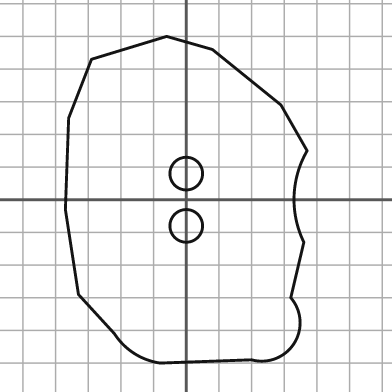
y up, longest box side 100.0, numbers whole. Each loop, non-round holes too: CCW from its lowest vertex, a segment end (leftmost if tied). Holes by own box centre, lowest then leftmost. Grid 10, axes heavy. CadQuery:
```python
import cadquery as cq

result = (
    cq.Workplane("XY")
    .moveTo(-8.0, -50.0)
    .lineTo(20.0, -49.0)
    .threePointArc((33.0, -44.0), (32.0, -30.0))
    .lineTo(36.0, -13.0)
    .threePointArc((33.0, 1.0), (37.0, 15.0))
    .lineTo(29.0, 29.0)
    .lineTo(8.0, 46.0)
    .lineTo(-6.0, 50.0)
    .lineTo(-29.0, 43.0)
    .lineTo(-36.0, 25.0)
    .lineTo(-37.0, -3.0)
    .lineTo(-33.0, -29.0)
    .lineTo(-22.0, -41.0)
    .threePointArc((-16.0, -47.0), (-8.0, -50.0))
    .close()
    .moveTo(0.0, -8.0)
    .circle(5.0)
    .moveTo(0.0, 8.0)
    .circle(5.0)
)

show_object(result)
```